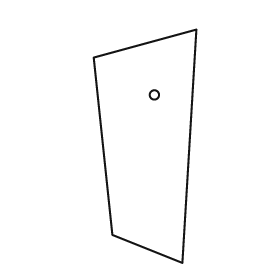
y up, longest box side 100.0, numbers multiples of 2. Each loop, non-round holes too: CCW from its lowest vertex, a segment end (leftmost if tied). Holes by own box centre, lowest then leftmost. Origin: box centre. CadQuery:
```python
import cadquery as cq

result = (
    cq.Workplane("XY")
    .moveTo(16.0, -50.0)
    .lineTo(22.0, 50.0)
    .lineTo(-22.0, 38.0)
    .lineTo(-14.0, -38.0)
    .close()
    .moveTo(4.0, 22.0)
    .circle(2.0)
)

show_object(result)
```